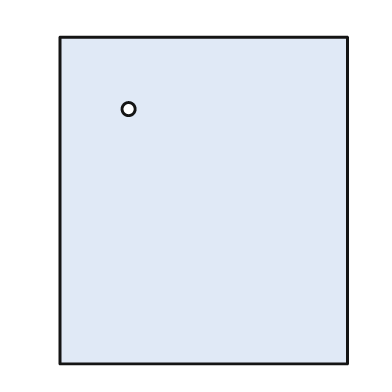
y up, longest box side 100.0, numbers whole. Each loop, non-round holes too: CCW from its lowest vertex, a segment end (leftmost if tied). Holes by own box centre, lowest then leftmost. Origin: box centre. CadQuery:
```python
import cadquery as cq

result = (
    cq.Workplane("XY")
    .moveTo(-44.0, -50.0)
    .lineTo(44.0, -50.0)
    .lineTo(44.0, 50.0)
    .lineTo(-44.0, 50.0)
    .close()
    .moveTo(-23.0, 28.0)
    .circle(2.0)
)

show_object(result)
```